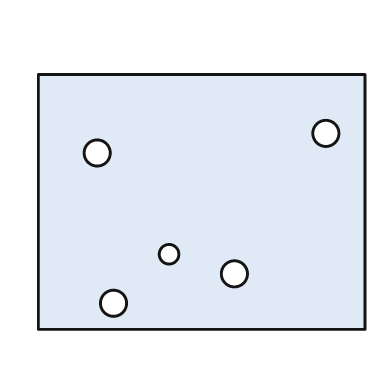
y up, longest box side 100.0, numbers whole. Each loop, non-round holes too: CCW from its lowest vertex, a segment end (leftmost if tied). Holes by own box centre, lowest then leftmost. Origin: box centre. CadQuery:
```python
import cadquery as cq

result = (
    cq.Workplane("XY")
    .moveTo(-50.0, -39.0)
    .lineTo(50.0, -39.0)
    .lineTo(50.0, 39.0)
    .lineTo(-50.0, 39.0)
    .close()
    .moveTo(-27.0, -31.0)
    .circle(4.0)
    .moveTo(10.0, -22.0)
    .circle(4.0)
    .moveTo(-10.0, -16.0)
    .circle(3.0)
    .moveTo(-32.0, 15.0)
    .circle(4.0)
    .moveTo(38.0, 21.0)
    .circle(4.0)
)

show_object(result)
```